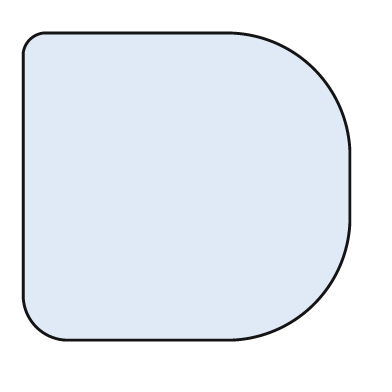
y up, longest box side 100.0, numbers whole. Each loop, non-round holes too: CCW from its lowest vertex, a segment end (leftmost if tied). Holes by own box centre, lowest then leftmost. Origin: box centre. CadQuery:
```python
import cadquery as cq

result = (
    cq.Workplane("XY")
    .moveTo(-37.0, -47.0)
    .lineTo(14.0, -47.0)
    .threePointArc((39.0, -36.0), (50.0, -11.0))
    .lineTo(50.0, 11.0)
    .threePointArc((39.0, 36.0), (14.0, 47.0))
    .lineTo(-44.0, 47.0)
    .threePointArc((-48.0, 45.0), (-50.0, 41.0))
    .lineTo(-50.0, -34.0)
    .threePointArc((-46.0, -43.0), (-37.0, -47.0))
    .close()
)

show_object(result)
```